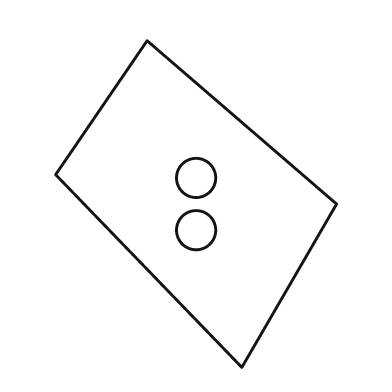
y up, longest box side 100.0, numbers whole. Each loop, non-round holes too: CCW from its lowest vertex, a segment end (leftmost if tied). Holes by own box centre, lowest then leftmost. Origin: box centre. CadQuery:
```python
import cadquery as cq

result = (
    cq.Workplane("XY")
    .moveTo(14.0, -50.0)
    .lineTo(43.0, 0.0)
    .lineTo(-15.0, 50.0)
    .lineTo(-43.0, 9.0)
    .close()
    .moveTo(0.0, -8.0)
    .circle(6.0)
    .moveTo(0.0, 8.0)
    .circle(6.0)
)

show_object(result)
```